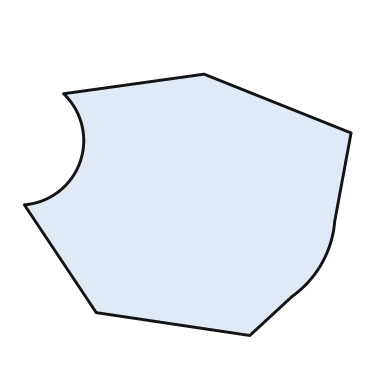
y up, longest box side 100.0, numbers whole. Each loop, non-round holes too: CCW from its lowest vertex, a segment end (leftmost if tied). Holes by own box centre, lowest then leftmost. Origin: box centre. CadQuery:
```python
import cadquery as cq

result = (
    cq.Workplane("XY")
    .moveTo(19.0, -40.0)
    .lineTo(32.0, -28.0)
    .threePointArc((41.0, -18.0), (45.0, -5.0))
    .lineTo(50.0, 22.0)
    .lineTo(5.0, 40.0)
    .lineTo(-38.0, 34.0)
    .threePointArc((-33.0, 13.0), (-50.0, 0.0))
    .lineTo(-28.0, -33.0)
    .close()
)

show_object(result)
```